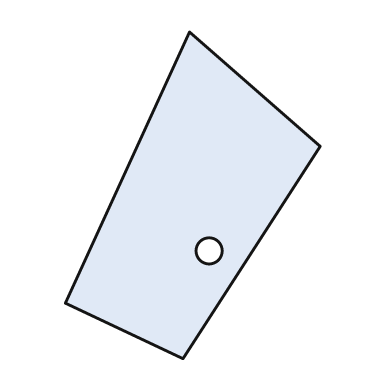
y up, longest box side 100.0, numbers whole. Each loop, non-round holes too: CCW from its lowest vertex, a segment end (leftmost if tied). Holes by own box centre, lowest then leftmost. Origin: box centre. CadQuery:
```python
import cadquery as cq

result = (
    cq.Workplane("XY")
    .moveTo(-3.0, -50.0)
    .lineTo(39.0, 15.0)
    .lineTo(-1.0, 50.0)
    .lineTo(-39.0, -33.0)
    .close()
    .moveTo(5.0, -17.0)
    .circle(4.0)
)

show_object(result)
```